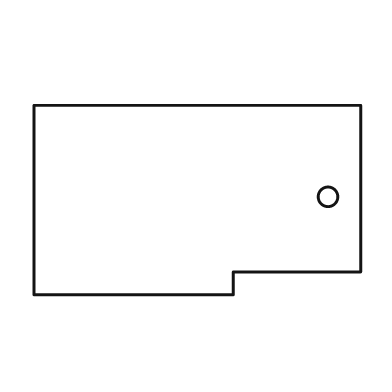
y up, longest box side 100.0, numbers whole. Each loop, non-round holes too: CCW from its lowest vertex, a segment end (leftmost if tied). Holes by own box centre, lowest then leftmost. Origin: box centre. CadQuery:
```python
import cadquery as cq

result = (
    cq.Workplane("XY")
    .moveTo(-50.0, -29.0)
    .lineTo(11.0, -29.0)
    .lineTo(11.0, -22.0)
    .lineTo(50.0, -22.0)
    .lineTo(50.0, 29.0)
    .lineTo(-50.0, 29.0)
    .close()
    .moveTo(40.0, 1.0)
    .circle(3.0)
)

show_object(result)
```